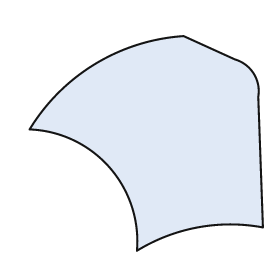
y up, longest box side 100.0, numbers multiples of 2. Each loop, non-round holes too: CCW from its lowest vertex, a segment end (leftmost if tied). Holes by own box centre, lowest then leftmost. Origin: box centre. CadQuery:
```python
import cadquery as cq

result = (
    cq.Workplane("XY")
    .moveTo(-4.0, -46.0)
    .threePointArc((22.0, -36.0), (50.0, -36.0))
    .lineTo(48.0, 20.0)
    .threePointArc((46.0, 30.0), (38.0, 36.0))
    .lineTo(16.0, 46.0)
    .threePointArc((-22.0, 34.0), (-50.0, 6.0))
    .threePointArc((-16.0, -10.0), (-4.0, -46.0))
    .close()
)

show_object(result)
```